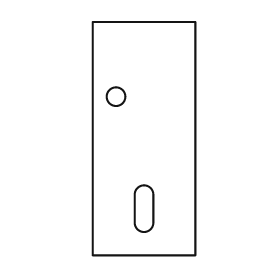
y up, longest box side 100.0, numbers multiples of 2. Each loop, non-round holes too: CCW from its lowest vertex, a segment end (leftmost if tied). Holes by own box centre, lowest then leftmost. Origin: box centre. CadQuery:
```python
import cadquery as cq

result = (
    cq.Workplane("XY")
    .moveTo(-22.0, -50.0)
    .lineTo(22.0, -50.0)
    .lineTo(22.0, 50.0)
    .lineTo(-22.0, 50.0)
    .close()
    .moveTo(-4.0, -36.0)
    .threePointArc((0.0, -40.0), (4.0, -36.0))
    .lineTo(4.0, -24.0)
    .threePointArc((0.0, -20.0), (-4.0, -24.0))
    .close()
    .moveTo(-12.0, 18.0)
    .circle(4.0)
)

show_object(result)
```